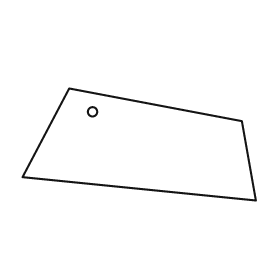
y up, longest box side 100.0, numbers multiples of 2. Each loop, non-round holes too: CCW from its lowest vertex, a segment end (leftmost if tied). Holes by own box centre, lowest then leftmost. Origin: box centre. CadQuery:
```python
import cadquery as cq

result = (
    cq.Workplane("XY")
    .moveTo(50.0, -24.0)
    .lineTo(44.0, 10.0)
    .lineTo(-30.0, 24.0)
    .lineTo(-50.0, -14.0)
    .close()
    .moveTo(-20.0, 14.0)
    .circle(2.0)
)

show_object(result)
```